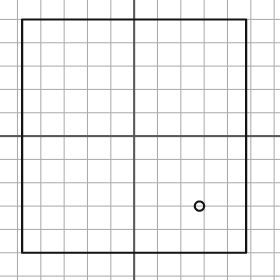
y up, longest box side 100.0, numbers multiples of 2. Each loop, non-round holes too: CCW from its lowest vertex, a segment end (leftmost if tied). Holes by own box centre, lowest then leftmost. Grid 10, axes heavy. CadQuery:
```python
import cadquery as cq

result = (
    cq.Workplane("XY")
    .moveTo(-48.0, -50.0)
    .lineTo(48.0, -50.0)
    .lineTo(48.0, 50.0)
    .lineTo(-48.0, 50.0)
    .close()
    .moveTo(28.0, -30.0)
    .circle(2.0)
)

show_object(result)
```